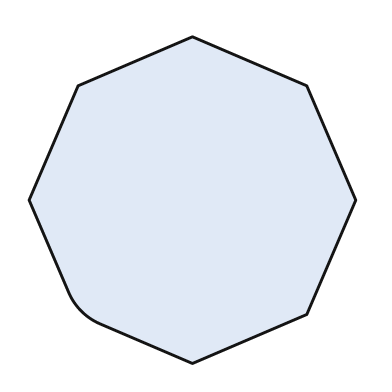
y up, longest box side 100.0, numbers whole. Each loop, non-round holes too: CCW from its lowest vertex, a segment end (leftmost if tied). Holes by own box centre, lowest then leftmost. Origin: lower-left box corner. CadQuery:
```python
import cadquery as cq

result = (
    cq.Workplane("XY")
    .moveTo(50.0, 0.0)
    .lineTo(85.0, 15.0)
    .lineTo(100.0, 50.0)
    .lineTo(85.0, 85.0)
    .lineTo(50.0, 100.0)
    .lineTo(15.0, 85.0)
    .lineTo(0.0, 50.0)
    .lineTo(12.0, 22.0)
    .threePointArc((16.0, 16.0), (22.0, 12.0))
    .close()
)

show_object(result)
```